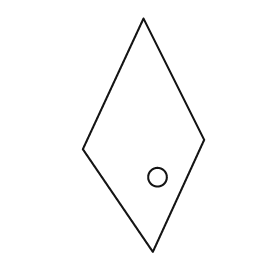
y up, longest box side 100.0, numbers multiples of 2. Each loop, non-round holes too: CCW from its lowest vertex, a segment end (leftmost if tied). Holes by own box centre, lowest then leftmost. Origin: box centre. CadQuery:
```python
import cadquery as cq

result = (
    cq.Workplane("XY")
    .moveTo(4.0, -50.0)
    .lineTo(26.0, -2.0)
    .lineTo(0.0, 50.0)
    .lineTo(-26.0, -6.0)
    .close()
    .moveTo(6.0, -18.0)
    .circle(4.0)
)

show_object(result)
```